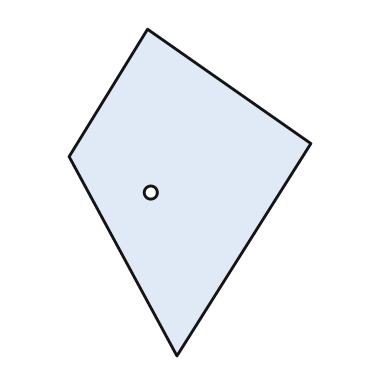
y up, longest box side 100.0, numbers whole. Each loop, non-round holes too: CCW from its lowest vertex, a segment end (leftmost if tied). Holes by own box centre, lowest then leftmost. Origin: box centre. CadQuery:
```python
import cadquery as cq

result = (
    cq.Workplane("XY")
    .moveTo(-4.0, -50.0)
    .lineTo(37.0, 15.0)
    .lineTo(-13.0, 50.0)
    .lineTo(-37.0, 11.0)
    .close()
    .moveTo(-12.0, 0.0)
    .circle(2.0)
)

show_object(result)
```